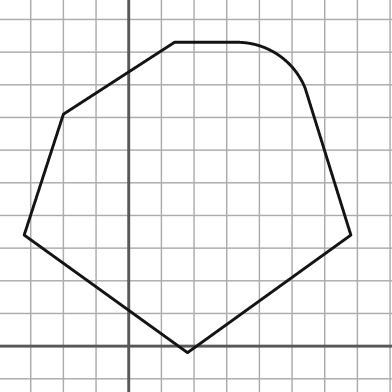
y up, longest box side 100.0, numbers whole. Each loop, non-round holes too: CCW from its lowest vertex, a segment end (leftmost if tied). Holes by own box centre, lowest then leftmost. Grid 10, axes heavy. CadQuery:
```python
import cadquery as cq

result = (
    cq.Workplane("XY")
    .moveTo(18.0, -2.0)
    .lineTo(68.0, 34.0)
    .lineTo(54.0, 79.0)
    .threePointArc((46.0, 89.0), (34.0, 93.0))
    .lineTo(14.0, 93.0)
    .lineTo(-20.0, 71.0)
    .lineTo(-32.0, 34.0)
    .close()
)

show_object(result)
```